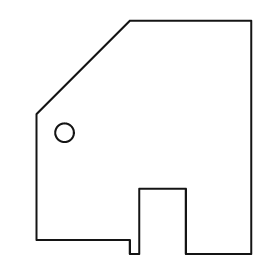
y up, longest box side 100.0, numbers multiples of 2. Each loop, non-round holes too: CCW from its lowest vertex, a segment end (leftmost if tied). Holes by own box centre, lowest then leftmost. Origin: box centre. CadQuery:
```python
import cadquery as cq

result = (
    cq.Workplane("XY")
    .moveTo(-6.0, -50.0)
    .lineTo(-2.0, -50.0)
    .lineTo(-2.0, -22.0)
    .lineTo(18.0, -22.0)
    .lineTo(18.0, -50.0)
    .lineTo(46.0, -50.0)
    .lineTo(46.0, 50.0)
    .lineTo(-6.0, 50.0)
    .lineTo(-46.0, 10.0)
    .lineTo(-46.0, -44.0)
    .lineTo(-6.0, -44.0)
    .close()
    .moveTo(-34.0, 2.0)
    .circle(4.0)
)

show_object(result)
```